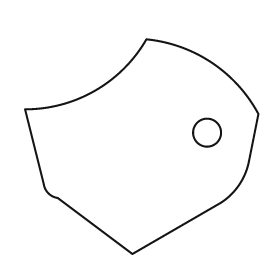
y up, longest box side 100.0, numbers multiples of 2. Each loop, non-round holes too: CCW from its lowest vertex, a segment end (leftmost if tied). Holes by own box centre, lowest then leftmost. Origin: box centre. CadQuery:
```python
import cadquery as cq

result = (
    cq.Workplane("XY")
    .moveTo(-4.0, -46.0)
    .lineTo(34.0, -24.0)
    .threePointArc((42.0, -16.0), (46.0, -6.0))
    .lineTo(50.0, 14.0)
    .threePointArc((30.0, 36.0), (2.0, 46.0))
    .threePointArc((-20.0, 24.0), (-50.0, 16.0))
    .lineTo(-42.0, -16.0)
    .threePointArc((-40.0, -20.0), (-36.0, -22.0))
    .close()
    .moveTo(28.0, 6.0)
    .circle(6.0)
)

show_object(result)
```